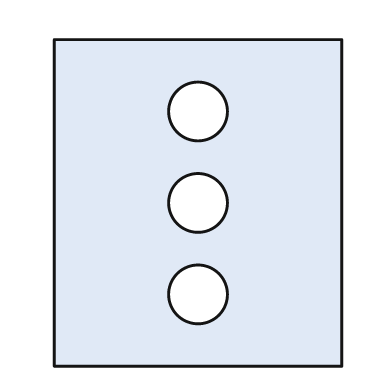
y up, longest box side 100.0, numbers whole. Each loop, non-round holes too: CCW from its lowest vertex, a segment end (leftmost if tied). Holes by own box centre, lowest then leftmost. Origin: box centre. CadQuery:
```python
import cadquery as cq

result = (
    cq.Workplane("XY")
    .moveTo(-44.0, -50.0)
    .lineTo(44.0, -50.0)
    .lineTo(44.0, 50.0)
    .lineTo(-44.0, 50.0)
    .close()
    .moveTo(0.0, -28.0)
    .circle(9.0)
    .moveTo(0.0, 0.0)
    .circle(9.0)
    .moveTo(0.0, 28.0)
    .circle(9.0)
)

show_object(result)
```